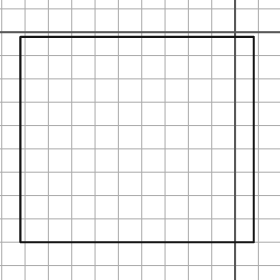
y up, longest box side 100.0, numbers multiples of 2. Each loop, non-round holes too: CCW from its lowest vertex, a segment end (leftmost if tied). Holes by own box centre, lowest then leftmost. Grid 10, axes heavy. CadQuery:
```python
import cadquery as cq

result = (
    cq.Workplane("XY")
    .moveTo(-92.0, -90.0)
    .lineTo(8.0, -90.0)
    .lineTo(8.0, -2.0)
    .lineTo(-92.0, -2.0)
    .close()
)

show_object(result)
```